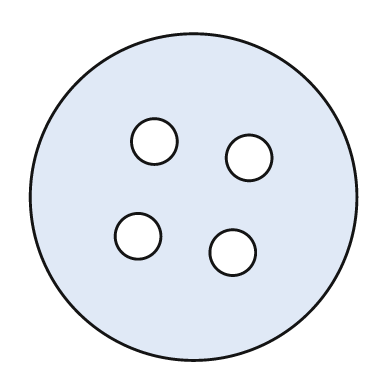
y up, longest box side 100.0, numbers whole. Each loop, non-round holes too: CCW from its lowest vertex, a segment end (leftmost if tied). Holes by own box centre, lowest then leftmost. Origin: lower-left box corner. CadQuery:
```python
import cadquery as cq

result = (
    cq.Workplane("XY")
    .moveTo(50.0, 50.0)
    .circle(50.0)
    .moveTo(62.0, 33.0)
    .circle(7.0)
    .moveTo(33.0, 38.0)
    .circle(7.0)
    .moveTo(67.0, 62.0)
    .circle(7.0)
    .moveTo(38.0, 67.0)
    .circle(7.0)
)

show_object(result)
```